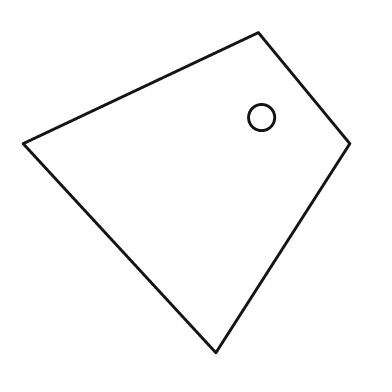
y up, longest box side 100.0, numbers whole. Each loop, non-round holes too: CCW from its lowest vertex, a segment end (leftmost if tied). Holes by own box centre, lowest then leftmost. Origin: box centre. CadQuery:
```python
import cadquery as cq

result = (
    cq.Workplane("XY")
    .moveTo(9.0, -49.0)
    .lineTo(50.0, 15.0)
    .lineTo(22.0, 49.0)
    .lineTo(-50.0, 15.0)
    .close()
    .moveTo(23.0, 23.0)
    .circle(4.0)
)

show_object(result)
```